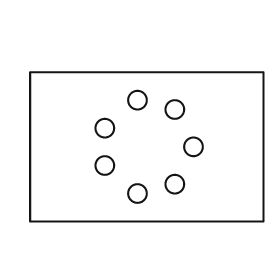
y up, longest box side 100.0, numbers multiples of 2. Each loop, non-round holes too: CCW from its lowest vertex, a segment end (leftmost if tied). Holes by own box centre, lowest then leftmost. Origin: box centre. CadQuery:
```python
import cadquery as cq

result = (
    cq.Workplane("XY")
    .moveTo(-50.0, -32.0)
    .lineTo(50.0, -32.0)
    .lineTo(50.0, 32.0)
    .lineTo(-50.0, 32.0)
    .close()
    .moveTo(-4.0, -20.0)
    .circle(4.0)
    .moveTo(12.0, -16.0)
    .circle(4.0)
    .moveTo(-18.0, -8.0)
    .circle(4.0)
    .moveTo(20.0, 0.0)
    .circle(4.0)
    .moveTo(-18.0, 8.0)
    .circle(4.0)
    .moveTo(12.0, 16.0)
    .circle(4.0)
    .moveTo(-4.0, 20.0)
    .circle(4.0)
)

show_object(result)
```